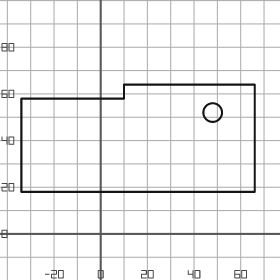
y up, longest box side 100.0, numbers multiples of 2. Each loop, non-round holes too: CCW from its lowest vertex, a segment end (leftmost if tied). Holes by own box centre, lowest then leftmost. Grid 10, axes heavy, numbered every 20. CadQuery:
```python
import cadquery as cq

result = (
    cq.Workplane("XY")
    .moveTo(-34.0, 18.0)
    .lineTo(66.0, 18.0)
    .lineTo(66.0, 64.0)
    .lineTo(10.0, 64.0)
    .lineTo(10.0, 58.0)
    .lineTo(-34.0, 58.0)
    .close()
    .moveTo(48.0, 52.0)
    .circle(4.0)
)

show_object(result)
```